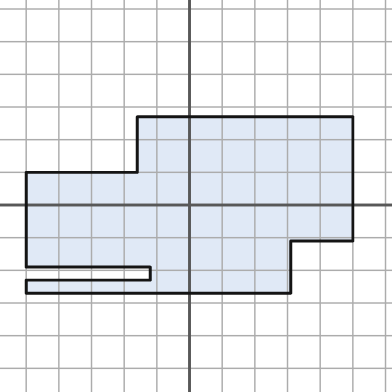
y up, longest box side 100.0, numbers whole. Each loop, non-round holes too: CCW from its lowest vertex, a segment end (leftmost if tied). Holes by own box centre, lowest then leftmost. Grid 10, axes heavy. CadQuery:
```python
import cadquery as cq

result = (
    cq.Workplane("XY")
    .moveTo(-50.0, -27.0)
    .lineTo(31.0, -27.0)
    .lineTo(31.0, -11.0)
    .lineTo(50.0, -11.0)
    .lineTo(50.0, 27.0)
    .lineTo(-16.0, 27.0)
    .lineTo(-16.0, 10.0)
    .lineTo(-50.0, 10.0)
    .lineTo(-50.0, -19.0)
    .lineTo(-12.0, -19.0)
    .lineTo(-12.0, -23.0)
    .lineTo(-50.0, -23.0)
    .close()
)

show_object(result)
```